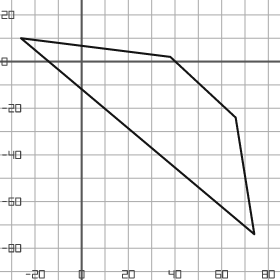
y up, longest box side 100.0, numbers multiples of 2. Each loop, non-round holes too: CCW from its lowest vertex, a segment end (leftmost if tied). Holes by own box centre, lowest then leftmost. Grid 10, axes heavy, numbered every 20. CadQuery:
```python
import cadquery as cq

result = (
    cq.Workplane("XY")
    .moveTo(74.0, -74.0)
    .lineTo(66.0, -24.0)
    .lineTo(38.0, 2.0)
    .lineTo(-26.0, 10.0)
    .close()
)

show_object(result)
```